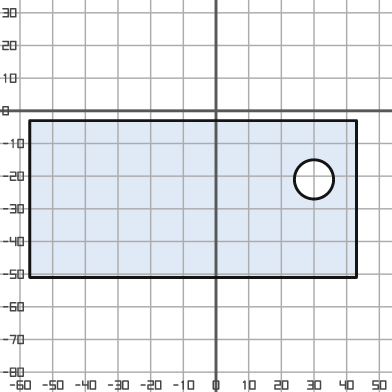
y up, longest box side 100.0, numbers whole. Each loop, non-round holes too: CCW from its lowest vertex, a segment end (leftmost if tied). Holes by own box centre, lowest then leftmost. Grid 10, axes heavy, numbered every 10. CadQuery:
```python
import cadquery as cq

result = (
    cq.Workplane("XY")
    .moveTo(-57.0, -51.0)
    .lineTo(43.0, -51.0)
    .lineTo(43.0, -3.0)
    .lineTo(-57.0, -3.0)
    .close()
    .moveTo(30.0, -21.0)
    .circle(6.0)
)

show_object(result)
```